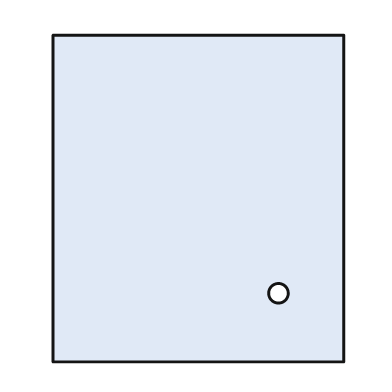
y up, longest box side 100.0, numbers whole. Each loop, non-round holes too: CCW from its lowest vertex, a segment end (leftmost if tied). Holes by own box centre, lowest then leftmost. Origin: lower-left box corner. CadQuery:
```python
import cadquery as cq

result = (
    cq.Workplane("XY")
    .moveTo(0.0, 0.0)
    .lineTo(89.0, 0.0)
    .lineTo(89.0, 100.0)
    .lineTo(0.0, 100.0)
    .close()
    .moveTo(69.0, 21.0)
    .circle(3.0)
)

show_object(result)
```